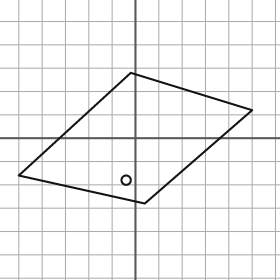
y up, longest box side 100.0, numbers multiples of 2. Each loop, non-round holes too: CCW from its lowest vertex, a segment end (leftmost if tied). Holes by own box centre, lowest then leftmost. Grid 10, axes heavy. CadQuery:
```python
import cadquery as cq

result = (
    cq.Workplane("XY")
    .moveTo(4.0, -28.0)
    .lineTo(50.0, 12.0)
    .lineTo(-2.0, 28.0)
    .lineTo(-50.0, -16.0)
    .close()
    .moveTo(-4.0, -18.0)
    .circle(2.0)
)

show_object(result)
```